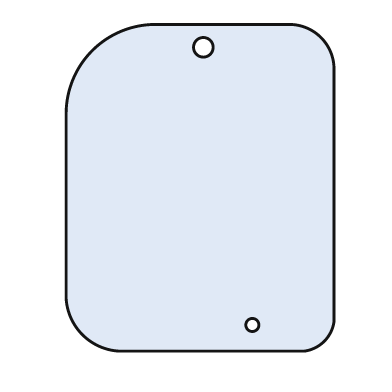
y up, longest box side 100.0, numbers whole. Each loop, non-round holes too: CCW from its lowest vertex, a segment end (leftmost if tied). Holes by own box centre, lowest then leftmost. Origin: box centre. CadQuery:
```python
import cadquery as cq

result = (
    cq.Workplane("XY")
    .moveTo(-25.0, -50.0)
    .lineTo(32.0, -50.0)
    .threePointArc((38.0, -47.0), (41.0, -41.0))
    .lineTo(41.0, 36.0)
    .threePointArc((37.0, 46.0), (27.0, 50.0))
    .lineTo(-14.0, 50.0)
    .threePointArc((-33.0, 42.0), (-41.0, 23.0))
    .lineTo(-41.0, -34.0)
    .threePointArc((-36.0, -45.0), (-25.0, -50.0))
    .close()
    .moveTo(16.0, -42.0)
    .circle(2.0)
    .moveTo(1.0, 43.0)
    .circle(3.0)
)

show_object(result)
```